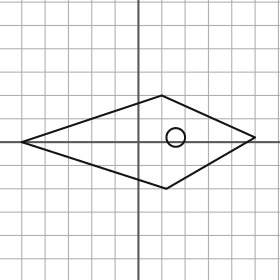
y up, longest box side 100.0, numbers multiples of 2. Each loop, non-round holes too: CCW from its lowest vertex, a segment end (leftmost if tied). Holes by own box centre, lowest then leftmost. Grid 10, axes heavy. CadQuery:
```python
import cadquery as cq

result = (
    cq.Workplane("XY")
    .moveTo(12.0, -20.0)
    .lineTo(50.0, 2.0)
    .lineTo(10.0, 20.0)
    .lineTo(-50.0, 0.0)
    .close()
    .moveTo(16.0, 2.0)
    .circle(4.0)
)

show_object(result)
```